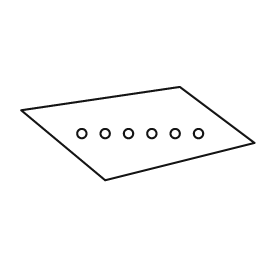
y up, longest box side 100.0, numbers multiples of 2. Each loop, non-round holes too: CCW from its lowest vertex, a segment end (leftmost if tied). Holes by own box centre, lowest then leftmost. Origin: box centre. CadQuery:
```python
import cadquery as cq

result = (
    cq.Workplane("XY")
    .moveTo(-14.0, -20.0)
    .lineTo(50.0, -4.0)
    .lineTo(18.0, 20.0)
    .lineTo(-50.0, 10.0)
    .close()
    .moveTo(-24.0, 0.0)
    .circle(2.0)
    .moveTo(-14.0, 0.0)
    .circle(2.0)
    .moveTo(-4.0, 0.0)
    .circle(2.0)
    .moveTo(6.0, 0.0)
    .circle(2.0)
    .moveTo(16.0, 0.0)
    .circle(2.0)
    .moveTo(26.0, 0.0)
    .circle(2.0)
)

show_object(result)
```